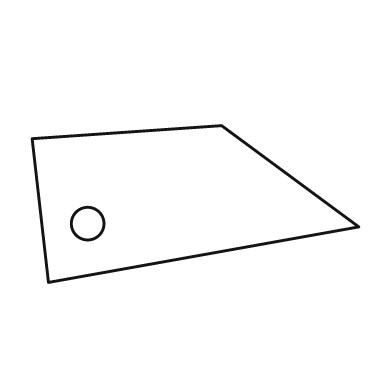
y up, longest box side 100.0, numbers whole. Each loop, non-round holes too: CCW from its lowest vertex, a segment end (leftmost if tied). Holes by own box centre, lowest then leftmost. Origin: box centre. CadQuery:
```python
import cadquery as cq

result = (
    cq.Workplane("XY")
    .moveTo(-45.0, -24.0)
    .lineTo(50.0, -7.0)
    .lineTo(8.0, 24.0)
    .lineTo(-50.0, 20.0)
    .close()
    .moveTo(-33.0, -6.0)
    .circle(5.0)
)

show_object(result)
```